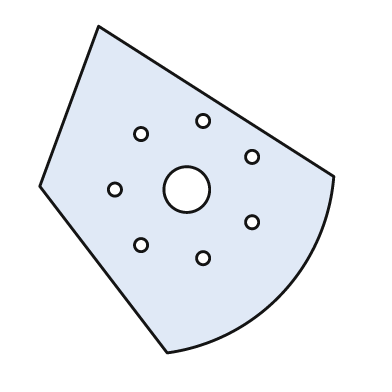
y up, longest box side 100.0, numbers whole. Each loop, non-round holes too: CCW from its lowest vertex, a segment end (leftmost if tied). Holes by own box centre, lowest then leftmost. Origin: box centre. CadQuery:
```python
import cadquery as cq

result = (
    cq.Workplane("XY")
    .moveTo(-6.0, -50.0)
    .threePointArc((29.0, -32.0), (45.0, 4.0))
    .lineTo(-27.0, 50.0)
    .lineTo(-45.0, 1.0)
    .close()
    .moveTo(5.0, -21.0)
    .circle(2.0)
    .moveTo(-14.0, -17.0)
    .circle(2.0)
    .moveTo(20.0, -10.0)
    .circle(2.0)
    .moveTo(-22.0, 0.0)
    .circle(2.0)
    .moveTo(0.0, 0.0)
    .circle(7.0)
    .moveTo(20.0, 10.0)
    .circle(2.0)
    .moveTo(-14.0, 17.0)
    .circle(2.0)
    .moveTo(5.0, 21.0)
    .circle(2.0)
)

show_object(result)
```